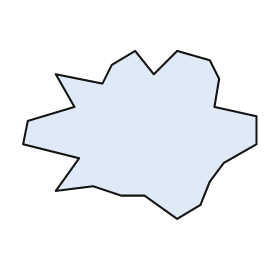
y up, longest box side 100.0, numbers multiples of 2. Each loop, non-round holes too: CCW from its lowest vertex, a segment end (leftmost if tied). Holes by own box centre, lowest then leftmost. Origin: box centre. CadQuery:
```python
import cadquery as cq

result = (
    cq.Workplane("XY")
    .moveTo(16.0, -36.0)
    .lineTo(26.0, -30.0)
    .lineTo(30.0, -20.0)
    .lineTo(36.0, -12.0)
    .lineTo(50.0, -4.0)
    .lineTo(50.0, 8.0)
    .lineTo(32.0, 12.0)
    .lineTo(34.0, 24.0)
    .lineTo(30.0, 32.0)
    .lineTo(16.0, 36.0)
    .lineTo(6.0, 26.0)
    .lineTo(-2.0, 36.0)
    .lineTo(-12.0, 30.0)
    .lineTo(-16.0, 22.0)
    .lineTo(-36.0, 26.0)
    .lineTo(-28.0, 12.0)
    .lineTo(-48.0, 6.0)
    .lineTo(-50.0, -4.0)
    .lineTo(-26.0, -10.0)
    .lineTo(-36.0, -24.0)
    .lineTo(-20.0, -22.0)
    .lineTo(-8.0, -26.0)
    .lineTo(2.0, -26.0)
    .close()
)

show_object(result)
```